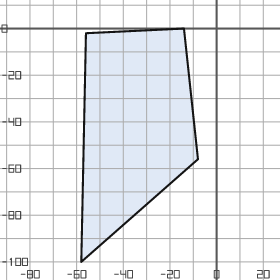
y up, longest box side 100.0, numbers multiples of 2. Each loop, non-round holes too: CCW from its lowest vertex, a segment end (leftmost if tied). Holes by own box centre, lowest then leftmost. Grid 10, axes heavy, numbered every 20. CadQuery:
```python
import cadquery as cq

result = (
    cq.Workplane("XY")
    .moveTo(-58.0, -100.0)
    .lineTo(-8.0, -56.0)
    .lineTo(-14.0, 0.0)
    .lineTo(-56.0, -2.0)
    .close()
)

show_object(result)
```